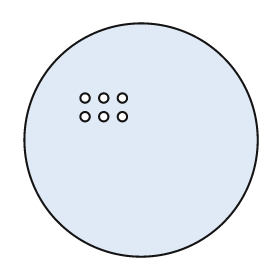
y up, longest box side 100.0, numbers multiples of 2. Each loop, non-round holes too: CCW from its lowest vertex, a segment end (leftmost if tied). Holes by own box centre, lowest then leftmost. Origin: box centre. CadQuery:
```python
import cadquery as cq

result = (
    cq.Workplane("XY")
    .moveTo(0.0, 0.0)
    .circle(50.0)
    .moveTo(-24.0, 10.0)
    .circle(2.0)
    .moveTo(-16.0, 10.0)
    .circle(2.0)
    .moveTo(-8.0, 10.0)
    .circle(2.0)
    .moveTo(-24.0, 18.0)
    .circle(2.0)
    .moveTo(-16.0, 18.0)
    .circle(2.0)
    .moveTo(-8.0, 18.0)
    .circle(2.0)
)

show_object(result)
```